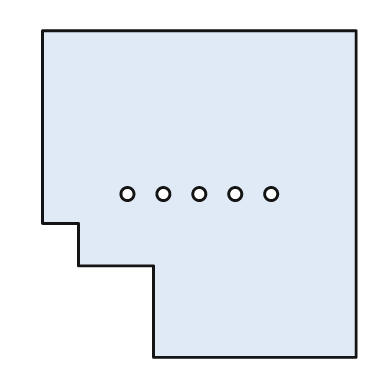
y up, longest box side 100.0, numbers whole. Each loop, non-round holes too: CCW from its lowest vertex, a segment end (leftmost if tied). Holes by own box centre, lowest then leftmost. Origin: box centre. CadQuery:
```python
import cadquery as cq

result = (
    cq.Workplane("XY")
    .moveTo(-14.0, -50.0)
    .lineTo(48.0, -50.0)
    .lineTo(48.0, 50.0)
    .lineTo(-48.0, 50.0)
    .lineTo(-48.0, -9.0)
    .lineTo(-37.0, -9.0)
    .lineTo(-37.0, -22.0)
    .lineTo(-14.0, -22.0)
    .close()
    .moveTo(-22.0, 0.0)
    .circle(2.0)
    .moveTo(-11.0, 0.0)
    .circle(2.0)
    .moveTo(0.0, 0.0)
    .circle(2.0)
    .moveTo(11.0, 0.0)
    .circle(2.0)
    .moveTo(22.0, 0.0)
    .circle(2.0)
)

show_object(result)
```